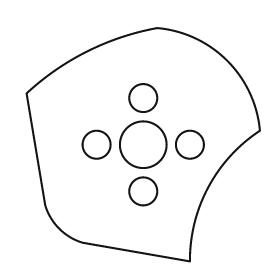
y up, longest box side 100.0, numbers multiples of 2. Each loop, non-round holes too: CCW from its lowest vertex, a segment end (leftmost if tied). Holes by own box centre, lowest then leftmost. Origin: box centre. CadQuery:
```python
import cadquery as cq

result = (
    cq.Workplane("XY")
    .moveTo(20.0, -50.0)
    .threePointArc((28.0, -18.0), (50.0, 6.0))
    .threePointArc((36.0, 36.0), (6.0, 50.0))
    .threePointArc((-24.0, 40.0), (-50.0, 22.0))
    .lineTo(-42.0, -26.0)
    .threePointArc((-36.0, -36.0), (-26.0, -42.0))
    .close()
    .moveTo(0.0, -20.0)
    .circle(6.0)
    .moveTo(-20.0, 0.0)
    .circle(6.0)
    .moveTo(0.0, 0.0)
    .circle(10.0)
    .moveTo(20.0, 0.0)
    .circle(6.0)
    .moveTo(0.0, 20.0)
    .circle(6.0)
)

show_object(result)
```